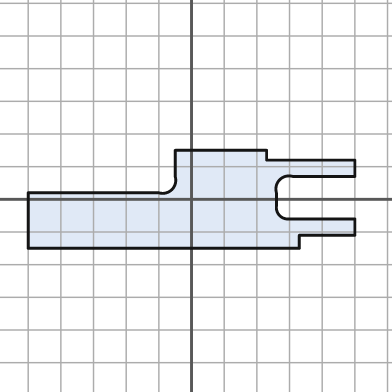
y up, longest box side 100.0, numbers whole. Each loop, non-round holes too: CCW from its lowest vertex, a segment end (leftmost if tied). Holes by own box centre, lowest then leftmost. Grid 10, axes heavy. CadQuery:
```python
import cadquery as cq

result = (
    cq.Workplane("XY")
    .moveTo(-50.0, -15.0)
    .lineTo(33.0, -15.0)
    .lineTo(33.0, -11.0)
    .lineTo(50.0, -11.0)
    .lineTo(50.0, -6.0)
    .lineTo(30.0, -6.0)
    .threePointArc((27.0, -5.0), (26.0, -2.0))
    .lineTo(26.0, 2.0)
    .threePointArc((27.0, 6.0), (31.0, 7.0))
    .lineTo(50.0, 7.0)
    .lineTo(50.0, 12.0)
    .lineTo(23.0, 12.0)
    .lineTo(23.0, 15.0)
    .lineTo(-5.0, 15.0)
    .lineTo(-5.0, 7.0)
    .threePointArc((-6.0, 3.0), (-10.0, 2.0))
    .lineTo(-50.0, 2.0)
    .close()
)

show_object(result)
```